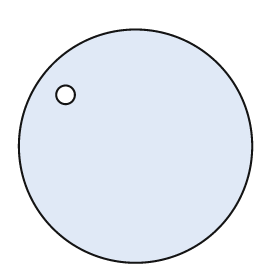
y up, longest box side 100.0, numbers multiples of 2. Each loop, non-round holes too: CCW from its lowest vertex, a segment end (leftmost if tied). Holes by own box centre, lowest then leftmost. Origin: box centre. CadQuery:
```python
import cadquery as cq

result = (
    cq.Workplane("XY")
    .moveTo(0.0, 0.0)
    .circle(50.0)
    .moveTo(-30.0, 22.0)
    .circle(4.0)
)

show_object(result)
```